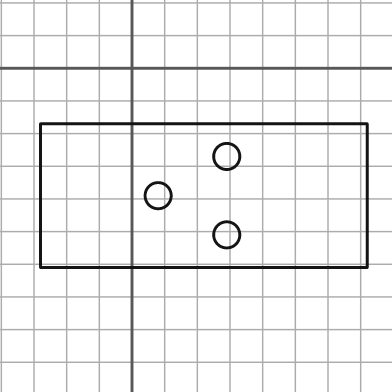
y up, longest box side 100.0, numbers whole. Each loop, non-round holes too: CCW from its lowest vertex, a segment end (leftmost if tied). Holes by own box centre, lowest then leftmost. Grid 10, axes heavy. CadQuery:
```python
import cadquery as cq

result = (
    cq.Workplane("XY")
    .moveTo(-28.0, -61.0)
    .lineTo(72.0, -61.0)
    .lineTo(72.0, -17.0)
    .lineTo(-28.0, -17.0)
    .close()
    .moveTo(29.0, -51.0)
    .circle(4.0)
    .moveTo(8.0, -39.0)
    .circle(4.0)
    .moveTo(29.0, -27.0)
    .circle(4.0)
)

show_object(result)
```